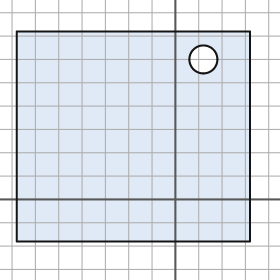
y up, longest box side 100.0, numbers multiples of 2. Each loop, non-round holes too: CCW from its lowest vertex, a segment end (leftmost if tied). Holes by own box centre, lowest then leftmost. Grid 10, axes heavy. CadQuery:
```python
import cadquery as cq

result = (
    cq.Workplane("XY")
    .moveTo(-68.0, -18.0)
    .lineTo(32.0, -18.0)
    .lineTo(32.0, 72.0)
    .lineTo(-68.0, 72.0)
    .close()
    .moveTo(12.0, 60.0)
    .circle(6.0)
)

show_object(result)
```